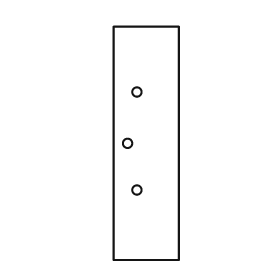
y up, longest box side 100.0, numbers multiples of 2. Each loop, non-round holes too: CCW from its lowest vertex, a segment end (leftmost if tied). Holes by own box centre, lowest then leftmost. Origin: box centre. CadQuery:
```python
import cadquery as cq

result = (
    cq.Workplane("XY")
    .moveTo(-14.0, -50.0)
    .lineTo(14.0, -50.0)
    .lineTo(14.0, 50.0)
    .lineTo(-14.0, 50.0)
    .close()
    .moveTo(-4.0, -20.0)
    .circle(2.0)
    .moveTo(-8.0, 0.0)
    .circle(2.0)
    .moveTo(-4.0, 22.0)
    .circle(2.0)
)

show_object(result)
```